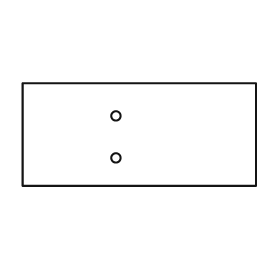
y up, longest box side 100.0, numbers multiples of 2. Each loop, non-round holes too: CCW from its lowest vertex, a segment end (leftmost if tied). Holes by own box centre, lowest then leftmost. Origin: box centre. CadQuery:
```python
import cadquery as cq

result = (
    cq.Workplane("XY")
    .moveTo(-50.0, -22.0)
    .lineTo(50.0, -22.0)
    .lineTo(50.0, 22.0)
    .lineTo(-50.0, 22.0)
    .close()
    .moveTo(-10.0, -10.0)
    .circle(2.0)
    .moveTo(-10.0, 8.0)
    .circle(2.0)
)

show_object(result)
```